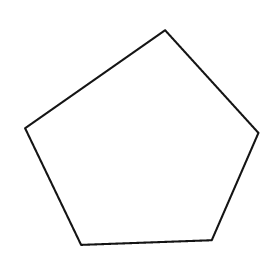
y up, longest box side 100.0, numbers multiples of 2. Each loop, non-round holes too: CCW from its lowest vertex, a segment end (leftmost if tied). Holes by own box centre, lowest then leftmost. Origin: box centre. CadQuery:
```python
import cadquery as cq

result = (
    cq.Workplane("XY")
    .moveTo(-26.0, -46.0)
    .lineTo(30.0, -44.0)
    .lineTo(50.0, 2.0)
    .lineTo(10.0, 46.0)
    .lineTo(-50.0, 4.0)
    .close()
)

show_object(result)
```